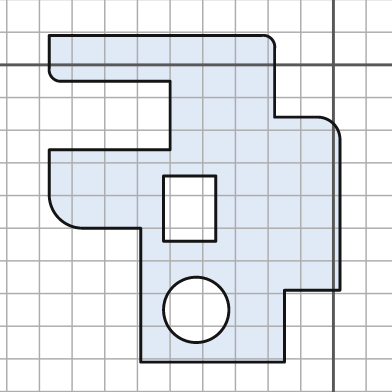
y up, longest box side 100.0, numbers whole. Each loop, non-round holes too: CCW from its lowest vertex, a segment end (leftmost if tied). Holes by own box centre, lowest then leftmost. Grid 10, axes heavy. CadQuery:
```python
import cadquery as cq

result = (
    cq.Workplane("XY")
    .moveTo(-59.0, -91.0)
    .lineTo(-15.0, -91.0)
    .lineTo(-15.0, -69.0)
    .lineTo(2.0, -69.0)
    .lineTo(2.0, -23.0)
    .threePointArc((0.0, -18.0), (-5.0, -16.0))
    .lineTo(-18.0, -16.0)
    .lineTo(-18.0, 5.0)
    .threePointArc((-19.0, 8.0), (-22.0, 9.0))
    .lineTo(-87.0, 9.0)
    .lineTo(-87.0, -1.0)
    .threePointArc((-86.0, -4.0), (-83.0, -5.0))
    .lineTo(-50.0, -5.0)
    .lineTo(-50.0, -26.0)
    .lineTo(-87.0, -26.0)
    .lineTo(-87.0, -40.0)
    .threePointArc((-84.0, -47.0), (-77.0, -50.0))
    .lineTo(-59.0, -50.0)
    .close()
    .moveTo(-42.0, -75.0)
    .circle(10.0)
    .moveTo(-52.0, -54.0)
    .lineTo(-36.0, -54.0)
    .lineTo(-36.0, -34.0)
    .lineTo(-52.0, -34.0)
    .close()
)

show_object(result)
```